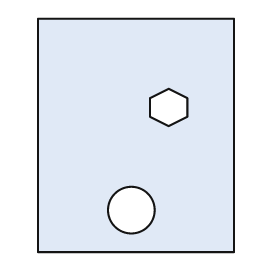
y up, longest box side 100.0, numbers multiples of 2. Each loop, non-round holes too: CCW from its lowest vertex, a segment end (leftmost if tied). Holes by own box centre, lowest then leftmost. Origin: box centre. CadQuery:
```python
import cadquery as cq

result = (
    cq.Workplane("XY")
    .moveTo(-42.0, -50.0)
    .lineTo(42.0, -50.0)
    .lineTo(42.0, 50.0)
    .lineTo(-42.0, 50.0)
    .close()
    .moveTo(-2.0, -32.0)
    .circle(10.0)
    .moveTo(14.0, 4.0)
    .lineTo(22.0, 8.0)
    .lineTo(22.0, 16.0)
    .lineTo(14.0, 20.0)
    .lineTo(6.0, 16.0)
    .lineTo(6.0, 8.0)
    .close()
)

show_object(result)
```